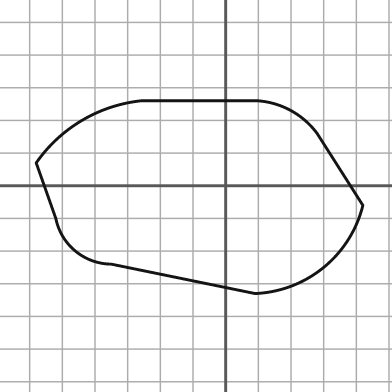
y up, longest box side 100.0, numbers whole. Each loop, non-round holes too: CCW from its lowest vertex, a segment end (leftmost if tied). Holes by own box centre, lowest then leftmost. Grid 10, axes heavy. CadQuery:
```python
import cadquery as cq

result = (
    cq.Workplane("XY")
    .moveTo(9.0, -33.0)
    .threePointArc((30.0, -25.0), (42.0, -6.0))
    .lineTo(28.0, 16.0)
    .threePointArc((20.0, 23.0), (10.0, 26.0))
    .lineTo(-26.0, 26.0)
    .threePointArc((-44.0, 20.0), (-58.0, 7.0))
    .lineTo(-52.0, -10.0)
    .threePointArc((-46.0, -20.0), (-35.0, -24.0))
    .close()
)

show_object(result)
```